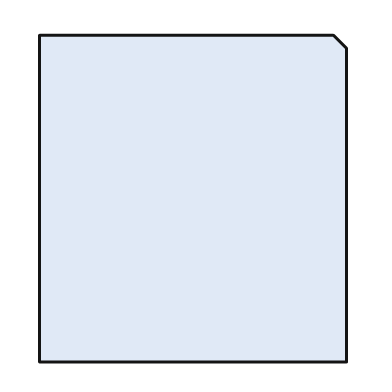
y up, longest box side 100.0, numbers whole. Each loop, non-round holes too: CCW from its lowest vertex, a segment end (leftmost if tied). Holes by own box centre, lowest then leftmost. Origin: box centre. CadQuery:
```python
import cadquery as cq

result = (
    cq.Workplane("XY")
    .moveTo(-47.0, -50.0)
    .lineTo(47.0, -50.0)
    .lineTo(47.0, 46.0)
    .lineTo(43.0, 50.0)
    .lineTo(-47.0, 50.0)
    .close()
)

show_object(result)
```